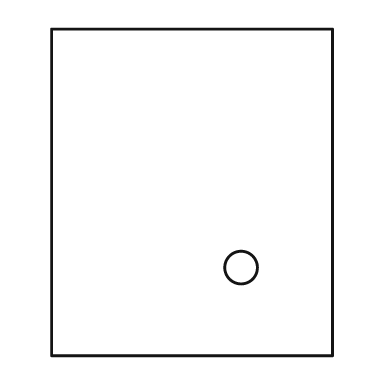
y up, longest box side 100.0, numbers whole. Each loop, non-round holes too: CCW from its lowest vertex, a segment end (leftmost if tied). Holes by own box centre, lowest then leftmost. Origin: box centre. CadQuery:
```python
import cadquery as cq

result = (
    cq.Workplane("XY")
    .moveTo(-43.0, -50.0)
    .lineTo(43.0, -50.0)
    .lineTo(43.0, 50.0)
    .lineTo(-43.0, 50.0)
    .close()
    .moveTo(15.0, -23.0)
    .circle(5.0)
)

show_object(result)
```